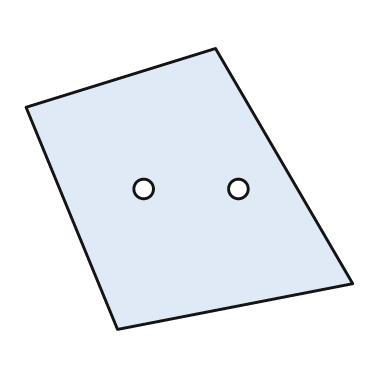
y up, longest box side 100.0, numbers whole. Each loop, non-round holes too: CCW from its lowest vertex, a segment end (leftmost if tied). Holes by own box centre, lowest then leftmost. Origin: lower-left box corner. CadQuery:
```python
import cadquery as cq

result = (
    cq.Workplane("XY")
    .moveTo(28.0, 0.0)
    .lineTo(100.0, 14.0)
    .lineTo(58.0, 86.0)
    .lineTo(0.0, 68.0)
    .close()
    .moveTo(36.0, 43.0)
    .circle(3.0)
    .moveTo(65.0, 43.0)
    .circle(3.0)
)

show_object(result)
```